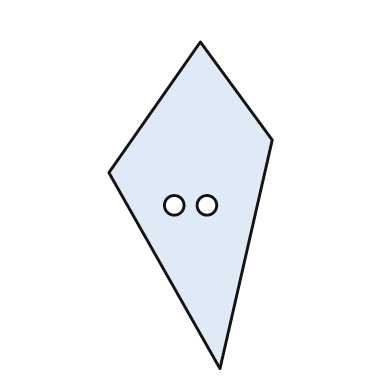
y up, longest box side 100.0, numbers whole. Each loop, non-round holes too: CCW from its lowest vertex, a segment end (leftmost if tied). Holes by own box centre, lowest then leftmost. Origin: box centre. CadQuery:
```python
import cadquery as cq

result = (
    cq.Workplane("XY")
    .moveTo(9.0, -50.0)
    .lineTo(25.0, 20.0)
    .lineTo(3.0, 50.0)
    .lineTo(-25.0, 10.0)
    .close()
    .moveTo(-5.0, 0.0)
    .circle(3.0)
    .moveTo(5.0, 0.0)
    .circle(3.0)
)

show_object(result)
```